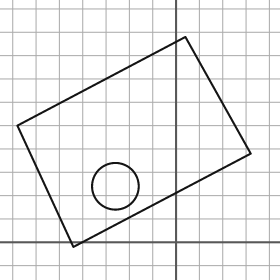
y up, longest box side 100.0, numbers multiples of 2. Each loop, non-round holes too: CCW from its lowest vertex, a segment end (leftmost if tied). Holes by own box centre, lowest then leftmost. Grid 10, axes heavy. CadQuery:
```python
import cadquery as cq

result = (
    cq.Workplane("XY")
    .moveTo(-44.0, -2.0)
    .lineTo(32.0, 38.0)
    .lineTo(4.0, 88.0)
    .lineTo(-68.0, 50.0)
    .close()
    .moveTo(-26.0, 24.0)
    .circle(10.0)
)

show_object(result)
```